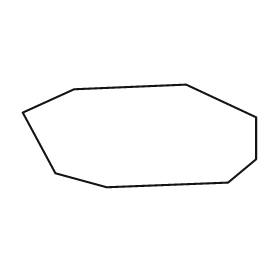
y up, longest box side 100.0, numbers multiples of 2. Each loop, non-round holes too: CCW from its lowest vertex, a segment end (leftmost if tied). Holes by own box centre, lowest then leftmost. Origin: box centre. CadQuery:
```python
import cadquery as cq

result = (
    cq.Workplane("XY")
    .moveTo(-14.0, -22.0)
    .lineTo(38.0, -20.0)
    .lineTo(50.0, -10.0)
    .lineTo(50.0, 8.0)
    .lineTo(20.0, 22.0)
    .lineTo(-28.0, 20.0)
    .lineTo(-50.0, 10.0)
    .lineTo(-36.0, -16.0)
    .close()
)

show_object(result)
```